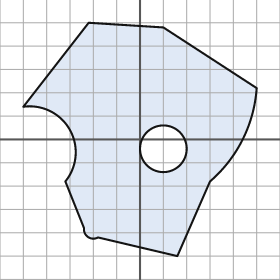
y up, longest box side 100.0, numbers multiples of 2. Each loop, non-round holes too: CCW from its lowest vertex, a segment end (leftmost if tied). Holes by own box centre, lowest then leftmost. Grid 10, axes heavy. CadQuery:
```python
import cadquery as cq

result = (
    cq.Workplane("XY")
    .moveTo(16.0, -50.0)
    .lineTo(30.0, -18.0)
    .threePointArc((44.0, 0.0), (50.0, 22.0))
    .lineTo(10.0, 48.0)
    .lineTo(-22.0, 50.0)
    .lineTo(-50.0, 14.0)
    .threePointArc((-30.0, 4.0), (-32.0, -18.0))
    .lineTo(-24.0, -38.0)
    .threePointArc((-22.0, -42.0), (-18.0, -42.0))
    .close()
    .moveTo(10.0, -4.0)
    .circle(10.0)
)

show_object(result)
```